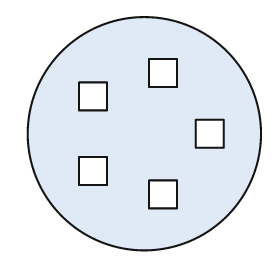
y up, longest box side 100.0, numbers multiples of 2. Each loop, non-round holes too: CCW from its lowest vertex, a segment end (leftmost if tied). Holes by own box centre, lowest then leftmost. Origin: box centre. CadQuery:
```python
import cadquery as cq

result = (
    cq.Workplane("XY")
    .moveTo(0.0, 0.0)
    .circle(50.0)
    .moveTo(2.0, -32.0)
    .lineTo(14.0, -32.0)
    .lineTo(14.0, -20.0)
    .lineTo(2.0, -20.0)
    .close()
    .moveTo(-28.0, -22.0)
    .lineTo(-16.0, -22.0)
    .lineTo(-16.0, -10.0)
    .lineTo(-28.0, -10.0)
    .close()
    .moveTo(22.0, -6.0)
    .lineTo(34.0, -6.0)
    .lineTo(34.0, 6.0)
    .lineTo(22.0, 6.0)
    .close()
    .moveTo(-28.0, 10.0)
    .lineTo(-16.0, 10.0)
    .lineTo(-16.0, 22.0)
    .lineTo(-28.0, 22.0)
    .close()
    .moveTo(2.0, 20.0)
    .lineTo(14.0, 20.0)
    .lineTo(14.0, 32.0)
    .lineTo(2.0, 32.0)
    .close()
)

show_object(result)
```